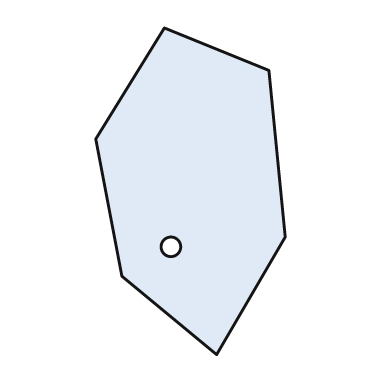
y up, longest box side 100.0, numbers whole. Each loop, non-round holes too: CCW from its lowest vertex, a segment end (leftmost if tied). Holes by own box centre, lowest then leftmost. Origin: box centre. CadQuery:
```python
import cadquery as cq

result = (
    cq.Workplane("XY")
    .moveTo(8.0, -50.0)
    .lineTo(29.0, -14.0)
    .lineTo(24.0, 37.0)
    .lineTo(-8.0, 50.0)
    .lineTo(-29.0, 16.0)
    .lineTo(-21.0, -26.0)
    .close()
    .moveTo(-6.0, -17.0)
    .circle(3.0)
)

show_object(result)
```